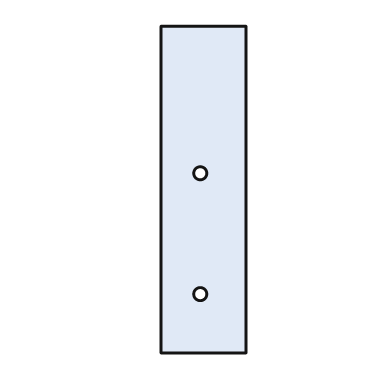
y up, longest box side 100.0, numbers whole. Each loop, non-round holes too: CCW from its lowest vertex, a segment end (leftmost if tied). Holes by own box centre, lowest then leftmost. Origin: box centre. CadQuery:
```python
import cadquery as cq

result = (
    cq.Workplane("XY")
    .moveTo(-13.0, -50.0)
    .lineTo(13.0, -50.0)
    .lineTo(13.0, 50.0)
    .lineTo(-13.0, 50.0)
    .close()
    .moveTo(-1.0, -32.0)
    .circle(2.0)
    .moveTo(-1.0, 5.0)
    .circle(2.0)
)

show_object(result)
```